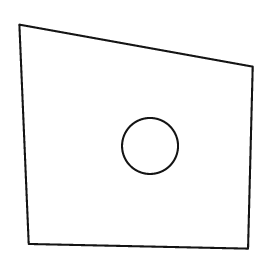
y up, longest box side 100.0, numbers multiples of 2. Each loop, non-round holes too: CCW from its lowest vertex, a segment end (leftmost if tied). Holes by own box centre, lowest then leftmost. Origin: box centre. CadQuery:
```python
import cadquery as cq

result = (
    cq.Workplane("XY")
    .moveTo(48.0, -48.0)
    .lineTo(50.0, 30.0)
    .lineTo(-50.0, 48.0)
    .lineTo(-46.0, -46.0)
    .close()
    .moveTo(6.0, -4.0)
    .circle(12.0)
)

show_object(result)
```